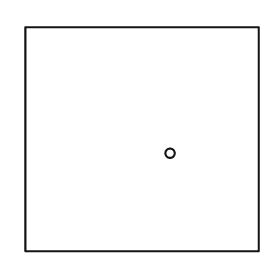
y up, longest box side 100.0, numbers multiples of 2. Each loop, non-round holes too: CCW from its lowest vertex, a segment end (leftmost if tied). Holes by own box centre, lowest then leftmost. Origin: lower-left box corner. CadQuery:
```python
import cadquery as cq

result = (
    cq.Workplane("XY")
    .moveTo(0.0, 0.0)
    .lineTo(100.0, 0.0)
    .lineTo(100.0, 96.0)
    .lineTo(0.0, 96.0)
    .close()
    .moveTo(62.0, 42.0)
    .circle(2.0)
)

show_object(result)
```